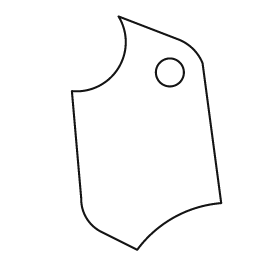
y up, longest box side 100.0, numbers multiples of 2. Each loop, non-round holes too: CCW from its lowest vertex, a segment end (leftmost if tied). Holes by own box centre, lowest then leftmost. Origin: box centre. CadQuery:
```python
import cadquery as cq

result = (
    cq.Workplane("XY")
    .moveTo(-4.0, -50.0)
    .threePointArc((12.0, -36.0), (32.0, -30.0))
    .lineTo(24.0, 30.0)
    .threePointArc((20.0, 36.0), (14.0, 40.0))
    .lineTo(-12.0, 50.0)
    .threePointArc((-12.0, 28.0), (-32.0, 18.0))
    .lineTo(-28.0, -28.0)
    .threePointArc((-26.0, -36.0), (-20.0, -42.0))
    .close()
    .moveTo(10.0, 26.0)
    .circle(6.0)
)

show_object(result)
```